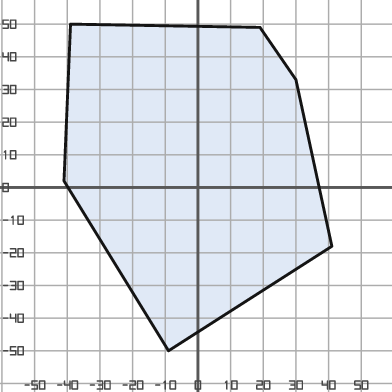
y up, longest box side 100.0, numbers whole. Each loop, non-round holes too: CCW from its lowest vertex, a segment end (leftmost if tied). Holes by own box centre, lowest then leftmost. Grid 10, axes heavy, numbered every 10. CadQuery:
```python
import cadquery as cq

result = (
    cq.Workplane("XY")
    .moveTo(-9.0, -50.0)
    .lineTo(41.0, -18.0)
    .lineTo(30.0, 33.0)
    .lineTo(19.0, 49.0)
    .lineTo(-39.0, 50.0)
    .lineTo(-41.0, 2.0)
    .close()
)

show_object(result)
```